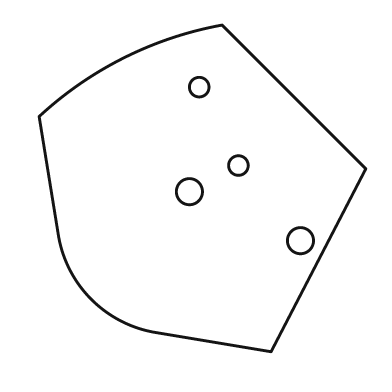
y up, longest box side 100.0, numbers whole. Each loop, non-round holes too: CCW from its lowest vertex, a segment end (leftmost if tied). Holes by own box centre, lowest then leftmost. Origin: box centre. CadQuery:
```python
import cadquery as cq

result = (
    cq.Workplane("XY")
    .moveTo(21.0, -50.0)
    .lineTo(50.0, 6.0)
    .lineTo(6.0, 50.0)
    .threePointArc((-24.0, 40.0), (-50.0, 22.0))
    .lineTo(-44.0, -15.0)
    .threePointArc((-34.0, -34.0), (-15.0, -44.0))
    .close()
    .moveTo(30.0, -16.0)
    .circle(4.0)
    .moveTo(-4.0, -1.0)
    .circle(4.0)
    .moveTo(11.0, 7.0)
    .circle(3.0)
    .moveTo(-1.0, 31.0)
    .circle(3.0)
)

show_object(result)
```